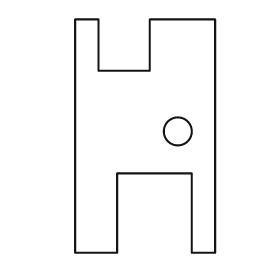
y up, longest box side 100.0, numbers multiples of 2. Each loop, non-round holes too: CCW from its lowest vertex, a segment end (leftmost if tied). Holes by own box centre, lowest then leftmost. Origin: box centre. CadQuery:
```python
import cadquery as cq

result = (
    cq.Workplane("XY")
    .moveTo(-30.0, -50.0)
    .lineTo(-12.0, -50.0)
    .lineTo(-12.0, -16.0)
    .lineTo(20.0, -16.0)
    .lineTo(20.0, -50.0)
    .lineTo(30.0, -50.0)
    .lineTo(30.0, 50.0)
    .lineTo(2.0, 50.0)
    .lineTo(2.0, 28.0)
    .lineTo(-20.0, 28.0)
    .lineTo(-20.0, 50.0)
    .lineTo(-30.0, 50.0)
    .close()
    .moveTo(14.0, 2.0)
    .circle(6.0)
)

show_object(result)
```